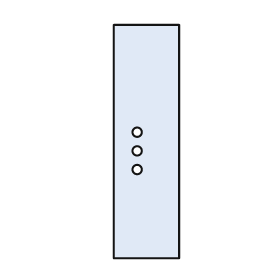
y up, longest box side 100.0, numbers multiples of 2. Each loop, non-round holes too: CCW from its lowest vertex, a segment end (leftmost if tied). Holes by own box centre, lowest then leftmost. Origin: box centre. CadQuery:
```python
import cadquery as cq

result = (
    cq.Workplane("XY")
    .moveTo(-14.0, -50.0)
    .lineTo(14.0, -50.0)
    .lineTo(14.0, 50.0)
    .lineTo(-14.0, 50.0)
    .close()
    .moveTo(-4.0, -12.0)
    .circle(2.0)
    .moveTo(-4.0, -4.0)
    .circle(2.0)
    .moveTo(-4.0, 4.0)
    .circle(2.0)
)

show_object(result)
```